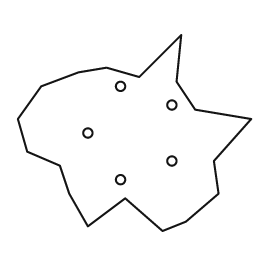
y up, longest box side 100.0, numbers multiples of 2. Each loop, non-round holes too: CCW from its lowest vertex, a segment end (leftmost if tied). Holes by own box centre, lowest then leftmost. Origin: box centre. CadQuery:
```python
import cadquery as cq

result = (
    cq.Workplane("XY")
    .moveTo(12.0, -42.0)
    .lineTo(22.0, -38.0)
    .lineTo(36.0, -26.0)
    .lineTo(34.0, -12.0)
    .lineTo(50.0, 6.0)
    .lineTo(26.0, 10.0)
    .lineTo(18.0, 22.0)
    .lineTo(20.0, 42.0)
    .lineTo(2.0, 24.0)
    .lineTo(-12.0, 28.0)
    .lineTo(-24.0, 26.0)
    .lineTo(-40.0, 20.0)
    .lineTo(-50.0, 6.0)
    .lineTo(-46.0, -8.0)
    .lineTo(-32.0, -14.0)
    .lineTo(-28.0, -26.0)
    .lineTo(-20.0, -40.0)
    .lineTo(-4.0, -28.0)
    .close()
    .moveTo(-6.0, -20.0)
    .circle(2.0)
    .moveTo(16.0, -12.0)
    .circle(2.0)
    .moveTo(-20.0, 0.0)
    .circle(2.0)
    .moveTo(16.0, 12.0)
    .circle(2.0)
    .moveTo(-6.0, 20.0)
    .circle(2.0)
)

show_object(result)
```